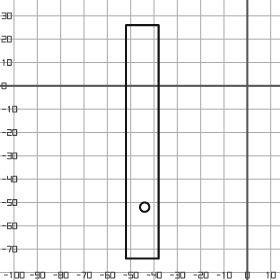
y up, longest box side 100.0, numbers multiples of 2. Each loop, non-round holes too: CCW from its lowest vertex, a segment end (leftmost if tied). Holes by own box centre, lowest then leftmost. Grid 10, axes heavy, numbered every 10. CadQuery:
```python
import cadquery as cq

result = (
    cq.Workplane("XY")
    .moveTo(-52.0, -74.0)
    .lineTo(-38.0, -74.0)
    .lineTo(-38.0, 26.0)
    .lineTo(-52.0, 26.0)
    .close()
    .moveTo(-44.0, -52.0)
    .circle(2.0)
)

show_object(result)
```